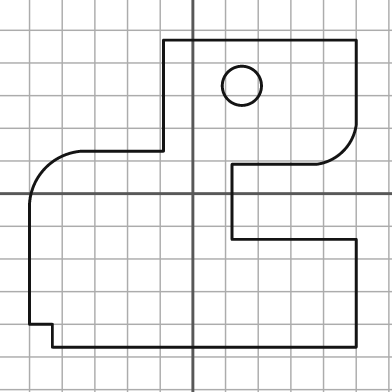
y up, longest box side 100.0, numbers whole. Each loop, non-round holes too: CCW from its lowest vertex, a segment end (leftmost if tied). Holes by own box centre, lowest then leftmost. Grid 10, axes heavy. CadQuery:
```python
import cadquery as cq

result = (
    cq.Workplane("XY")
    .moveTo(-43.0, -47.0)
    .lineTo(50.0, -47.0)
    .lineTo(50.0, -14.0)
    .lineTo(12.0, -14.0)
    .lineTo(12.0, 9.0)
    .lineTo(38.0, 9.0)
    .threePointArc((46.0, 13.0), (50.0, 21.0))
    .lineTo(50.0, 47.0)
    .lineTo(-9.0, 47.0)
    .lineTo(-9.0, 13.0)
    .lineTo(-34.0, 13.0)
    .threePointArc((-45.0, 8.0), (-50.0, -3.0))
    .lineTo(-50.0, -40.0)
    .lineTo(-43.0, -40.0)
    .close()
    .moveTo(15.0, 33.0)
    .circle(6.0)
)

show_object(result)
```